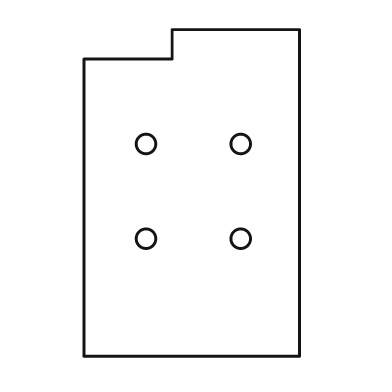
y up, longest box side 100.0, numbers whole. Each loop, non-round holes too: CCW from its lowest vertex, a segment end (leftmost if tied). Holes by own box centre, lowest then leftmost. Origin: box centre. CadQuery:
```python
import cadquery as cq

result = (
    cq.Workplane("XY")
    .moveTo(-33.0, -50.0)
    .lineTo(33.0, -50.0)
    .lineTo(33.0, 50.0)
    .lineTo(-6.0, 50.0)
    .lineTo(-6.0, 41.0)
    .lineTo(-33.0, 41.0)
    .close()
    .moveTo(-14.0, -14.0)
    .circle(3.0)
    .moveTo(15.0, -14.0)
    .circle(3.0)
    .moveTo(-14.0, 15.0)
    .circle(3.0)
    .moveTo(15.0, 15.0)
    .circle(3.0)
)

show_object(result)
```